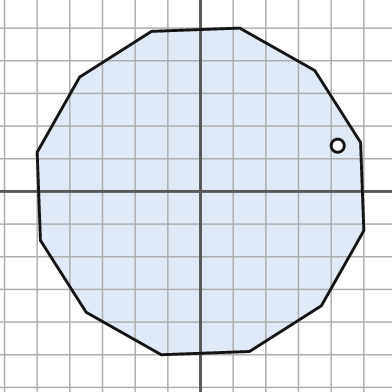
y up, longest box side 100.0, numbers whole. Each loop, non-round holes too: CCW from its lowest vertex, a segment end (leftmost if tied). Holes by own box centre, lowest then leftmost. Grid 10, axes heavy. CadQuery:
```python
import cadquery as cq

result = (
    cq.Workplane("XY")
    .moveTo(-12.0, -50.0)
    .lineTo(15.0, -49.0)
    .lineTo(37.0, -35.0)
    .lineTo(50.0, -12.0)
    .lineTo(49.0, 15.0)
    .lineTo(35.0, 37.0)
    .lineTo(12.0, 50.0)
    .lineTo(-15.0, 49.0)
    .lineTo(-37.0, 35.0)
    .lineTo(-50.0, 12.0)
    .lineTo(-49.0, -15.0)
    .lineTo(-35.0, -37.0)
    .close()
    .moveTo(42.0, 14.0)
    .circle(2.0)
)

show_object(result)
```